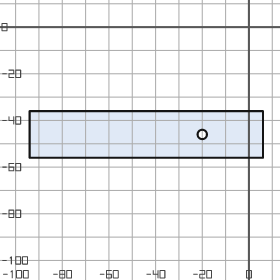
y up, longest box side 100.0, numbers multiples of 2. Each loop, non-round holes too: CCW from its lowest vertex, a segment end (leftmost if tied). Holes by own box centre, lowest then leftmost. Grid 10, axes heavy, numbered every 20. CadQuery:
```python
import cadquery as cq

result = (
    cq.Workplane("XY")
    .moveTo(-94.0, -56.0)
    .lineTo(6.0, -56.0)
    .lineTo(6.0, -36.0)
    .lineTo(-94.0, -36.0)
    .close()
    .moveTo(-20.0, -46.0)
    .circle(2.0)
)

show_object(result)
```